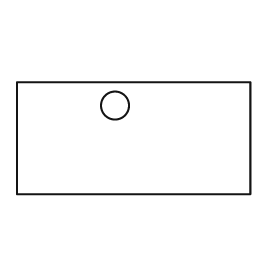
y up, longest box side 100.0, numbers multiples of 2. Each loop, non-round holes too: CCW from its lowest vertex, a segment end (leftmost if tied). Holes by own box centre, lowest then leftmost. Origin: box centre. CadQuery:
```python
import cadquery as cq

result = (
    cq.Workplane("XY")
    .moveTo(-50.0, -24.0)
    .lineTo(50.0, -24.0)
    .lineTo(50.0, 24.0)
    .lineTo(-50.0, 24.0)
    .close()
    .moveTo(-8.0, 14.0)
    .circle(6.0)
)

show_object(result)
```